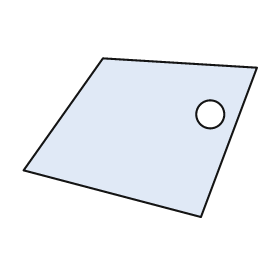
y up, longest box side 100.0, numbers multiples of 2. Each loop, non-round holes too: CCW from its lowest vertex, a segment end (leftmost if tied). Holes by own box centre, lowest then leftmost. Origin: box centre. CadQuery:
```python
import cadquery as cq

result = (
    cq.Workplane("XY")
    .moveTo(26.0, -34.0)
    .lineTo(50.0, 30.0)
    .lineTo(-16.0, 34.0)
    .lineTo(-50.0, -14.0)
    .close()
    .moveTo(30.0, 10.0)
    .circle(6.0)
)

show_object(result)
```